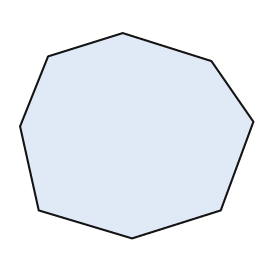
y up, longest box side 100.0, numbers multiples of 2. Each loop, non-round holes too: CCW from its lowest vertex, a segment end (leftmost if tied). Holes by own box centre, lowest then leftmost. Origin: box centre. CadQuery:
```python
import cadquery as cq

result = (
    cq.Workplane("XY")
    .moveTo(-2.0, -44.0)
    .lineTo(36.0, -32.0)
    .lineTo(50.0, 6.0)
    .lineTo(32.0, 32.0)
    .lineTo(-6.0, 44.0)
    .lineTo(-38.0, 34.0)
    .lineTo(-50.0, 4.0)
    .lineTo(-42.0, -32.0)
    .close()
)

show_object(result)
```